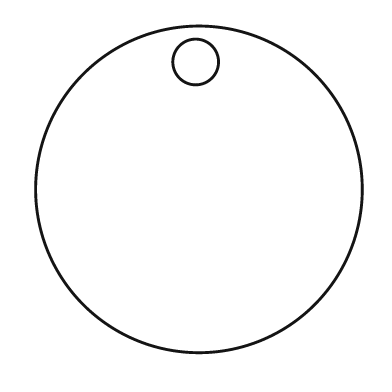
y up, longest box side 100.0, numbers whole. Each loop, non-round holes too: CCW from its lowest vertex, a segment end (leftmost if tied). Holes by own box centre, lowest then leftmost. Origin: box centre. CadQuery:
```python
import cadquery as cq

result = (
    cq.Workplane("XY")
    .moveTo(0.0, 0.0)
    .circle(50.0)
    .moveTo(-1.0, 39.0)
    .circle(7.0)
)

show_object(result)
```